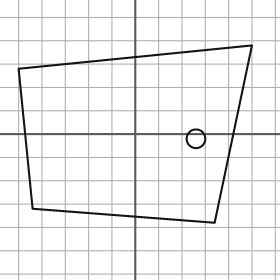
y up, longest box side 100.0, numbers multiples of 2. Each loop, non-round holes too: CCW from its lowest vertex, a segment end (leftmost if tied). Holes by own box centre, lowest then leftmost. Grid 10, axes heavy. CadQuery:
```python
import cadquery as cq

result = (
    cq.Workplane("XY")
    .moveTo(34.0, -38.0)
    .lineTo(50.0, 38.0)
    .lineTo(-50.0, 28.0)
    .lineTo(-44.0, -32.0)
    .close()
    .moveTo(26.0, -2.0)
    .circle(4.0)
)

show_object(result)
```